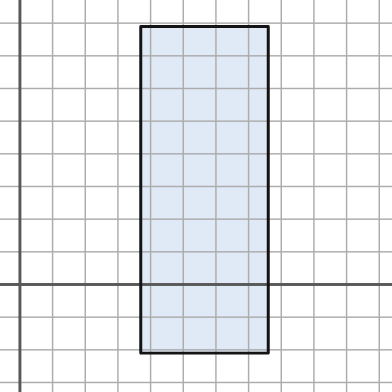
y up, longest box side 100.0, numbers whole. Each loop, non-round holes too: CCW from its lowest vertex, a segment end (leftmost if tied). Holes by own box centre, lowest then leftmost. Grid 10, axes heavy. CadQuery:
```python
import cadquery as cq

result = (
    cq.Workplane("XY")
    .moveTo(37.0, -21.0)
    .lineTo(76.0, -21.0)
    .lineTo(76.0, 79.0)
    .lineTo(37.0, 79.0)
    .close()
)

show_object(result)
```